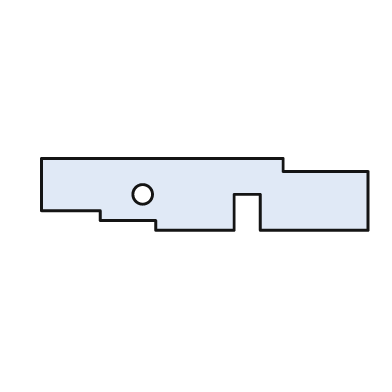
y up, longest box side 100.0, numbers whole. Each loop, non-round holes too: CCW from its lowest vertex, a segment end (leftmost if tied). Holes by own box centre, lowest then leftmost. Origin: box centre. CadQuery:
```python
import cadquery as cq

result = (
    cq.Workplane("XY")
    .moveTo(-15.0, -11.0)
    .lineTo(9.0, -11.0)
    .lineTo(9.0, 0.0)
    .lineTo(17.0, 0.0)
    .lineTo(17.0, -11.0)
    .lineTo(50.0, -11.0)
    .lineTo(50.0, 7.0)
    .lineTo(24.0, 7.0)
    .lineTo(24.0, 11.0)
    .lineTo(-50.0, 11.0)
    .lineTo(-50.0, -5.0)
    .lineTo(-32.0, -5.0)
    .lineTo(-32.0, -8.0)
    .lineTo(-15.0, -8.0)
    .close()
    .moveTo(-19.0, 0.0)
    .circle(3.0)
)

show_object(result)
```